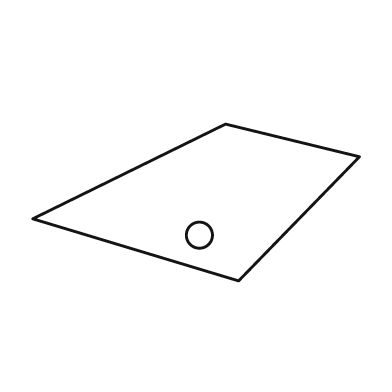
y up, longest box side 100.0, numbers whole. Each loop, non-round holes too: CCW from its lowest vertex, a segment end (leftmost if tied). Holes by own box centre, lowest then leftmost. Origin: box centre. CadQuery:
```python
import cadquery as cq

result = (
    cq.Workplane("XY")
    .moveTo(13.0, -24.0)
    .lineTo(50.0, 14.0)
    .lineTo(9.0, 24.0)
    .lineTo(-50.0, -5.0)
    .close()
    .moveTo(1.0, -10.0)
    .circle(4.0)
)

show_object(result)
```